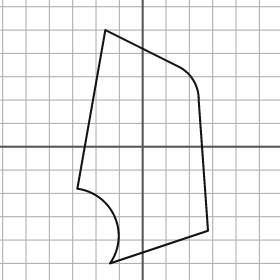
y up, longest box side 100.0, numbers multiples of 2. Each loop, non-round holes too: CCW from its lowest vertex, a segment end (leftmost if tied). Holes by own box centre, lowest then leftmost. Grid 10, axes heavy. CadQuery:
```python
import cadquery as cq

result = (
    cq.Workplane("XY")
    .moveTo(-14.0, -50.0)
    .lineTo(28.0, -36.0)
    .lineTo(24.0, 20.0)
    .threePointArc((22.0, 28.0), (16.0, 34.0))
    .lineTo(-16.0, 50.0)
    .lineTo(-28.0, -18.0)
    .threePointArc((-12.0, -30.0), (-14.0, -50.0))
    .close()
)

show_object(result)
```